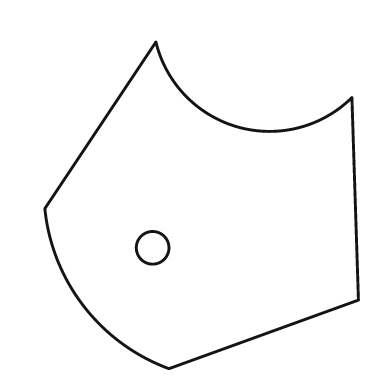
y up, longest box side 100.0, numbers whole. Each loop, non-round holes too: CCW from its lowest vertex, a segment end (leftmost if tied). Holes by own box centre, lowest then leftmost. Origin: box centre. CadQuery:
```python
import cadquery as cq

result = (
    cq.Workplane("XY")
    .moveTo(-10.0, -50.0)
    .lineTo(48.0, -29.0)
    .lineTo(46.0, 33.0)
    .threePointArc((11.0, 24.0), (-14.0, 50.0))
    .lineTo(-48.0, -1.0)
    .threePointArc((-36.0, -31.0), (-10.0, -50.0))
    .close()
    .moveTo(-15.0, -13.0)
    .circle(5.0)
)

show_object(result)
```